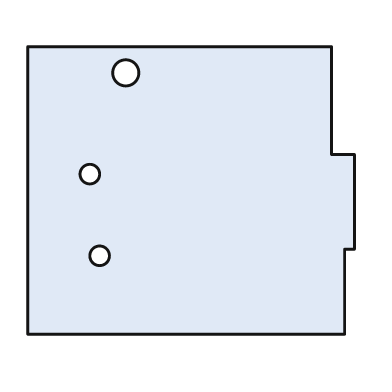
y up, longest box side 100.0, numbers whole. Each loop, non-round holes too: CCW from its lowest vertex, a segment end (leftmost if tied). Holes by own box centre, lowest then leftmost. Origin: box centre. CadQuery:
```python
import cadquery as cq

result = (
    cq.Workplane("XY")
    .moveTo(-50.0, -44.0)
    .lineTo(47.0, -44.0)
    .lineTo(47.0, -18.0)
    .lineTo(50.0, -18.0)
    .lineTo(50.0, 11.0)
    .lineTo(43.0, 11.0)
    .lineTo(43.0, 44.0)
    .lineTo(-50.0, 44.0)
    .close()
    .moveTo(-28.0, -20.0)
    .circle(3.0)
    .moveTo(-31.0, 5.0)
    .circle(3.0)
    .moveTo(-20.0, 36.0)
    .circle(4.0)
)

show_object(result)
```